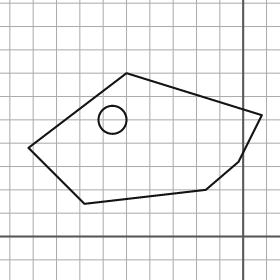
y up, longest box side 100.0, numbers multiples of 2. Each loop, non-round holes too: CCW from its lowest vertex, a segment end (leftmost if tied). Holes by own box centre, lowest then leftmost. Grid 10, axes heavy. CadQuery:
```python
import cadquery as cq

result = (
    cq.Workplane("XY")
    .moveTo(-68.0, 14.0)
    .lineTo(-16.0, 20.0)
    .lineTo(-2.0, 32.0)
    .lineTo(8.0, 52.0)
    .lineTo(-50.0, 70.0)
    .lineTo(-92.0, 38.0)
    .close()
    .moveTo(-56.0, 50.0)
    .circle(6.0)
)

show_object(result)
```